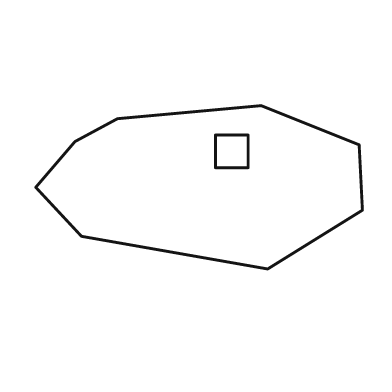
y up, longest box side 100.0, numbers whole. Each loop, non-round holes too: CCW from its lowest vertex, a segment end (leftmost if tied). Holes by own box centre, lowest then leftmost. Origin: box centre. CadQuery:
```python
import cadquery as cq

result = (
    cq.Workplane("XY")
    .moveTo(21.0, -25.0)
    .lineTo(50.0, -7.0)
    .lineTo(49.0, 13.0)
    .lineTo(19.0, 25.0)
    .lineTo(-25.0, 21.0)
    .lineTo(-38.0, 14.0)
    .lineTo(-50.0, 0.0)
    .lineTo(-36.0, -15.0)
    .close()
    .moveTo(5.0, 6.0)
    .lineTo(15.0, 6.0)
    .lineTo(15.0, 16.0)
    .lineTo(5.0, 16.0)
    .close()
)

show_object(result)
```